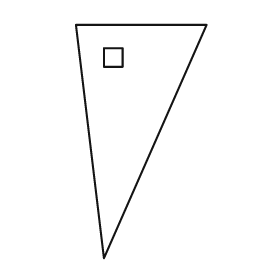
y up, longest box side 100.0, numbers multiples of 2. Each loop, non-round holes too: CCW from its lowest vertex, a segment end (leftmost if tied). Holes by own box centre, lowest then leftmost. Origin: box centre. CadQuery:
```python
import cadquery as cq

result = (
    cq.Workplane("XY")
    .moveTo(-16.0, -50.0)
    .lineTo(28.0, 50.0)
    .lineTo(-28.0, 50.0)
    .close()
    .moveTo(-16.0, 32.0)
    .lineTo(-8.0, 32.0)
    .lineTo(-8.0, 40.0)
    .lineTo(-16.0, 40.0)
    .close()
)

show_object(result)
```